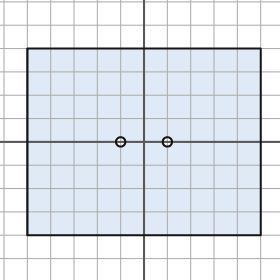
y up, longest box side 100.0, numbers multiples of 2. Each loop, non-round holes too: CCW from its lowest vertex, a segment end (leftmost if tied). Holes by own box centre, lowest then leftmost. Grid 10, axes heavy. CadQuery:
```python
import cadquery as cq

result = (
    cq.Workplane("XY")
    .moveTo(-50.0, -40.0)
    .lineTo(50.0, -40.0)
    .lineTo(50.0, 40.0)
    .lineTo(-50.0, 40.0)
    .close()
    .moveTo(-10.0, 0.0)
    .circle(2.0)
    .moveTo(10.0, 0.0)
    .circle(2.0)
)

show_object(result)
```